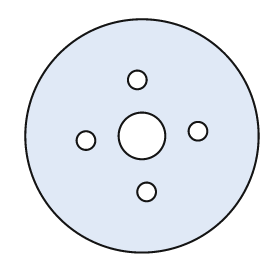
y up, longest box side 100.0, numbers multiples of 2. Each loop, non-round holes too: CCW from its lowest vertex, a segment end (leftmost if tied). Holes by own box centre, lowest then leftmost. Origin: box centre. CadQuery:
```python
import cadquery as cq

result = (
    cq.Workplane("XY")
    .moveTo(0.0, 0.0)
    .circle(50.0)
    .moveTo(2.0, -24.0)
    .circle(4.0)
    .moveTo(-24.0, -2.0)
    .circle(4.0)
    .moveTo(0.0, 0.0)
    .circle(10.0)
    .moveTo(24.0, 2.0)
    .circle(4.0)
    .moveTo(-2.0, 24.0)
    .circle(4.0)
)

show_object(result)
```